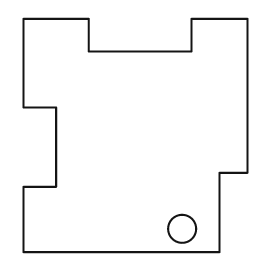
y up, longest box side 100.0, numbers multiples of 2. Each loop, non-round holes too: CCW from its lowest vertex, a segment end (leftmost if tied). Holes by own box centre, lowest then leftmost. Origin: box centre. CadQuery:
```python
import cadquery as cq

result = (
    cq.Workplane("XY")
    .moveTo(-48.0, -50.0)
    .lineTo(36.0, -50.0)
    .lineTo(36.0, -16.0)
    .lineTo(48.0, -16.0)
    .lineTo(48.0, 50.0)
    .lineTo(24.0, 50.0)
    .lineTo(24.0, 36.0)
    .lineTo(-20.0, 36.0)
    .lineTo(-20.0, 50.0)
    .lineTo(-48.0, 50.0)
    .lineTo(-48.0, 12.0)
    .lineTo(-34.0, 12.0)
    .lineTo(-34.0, -22.0)
    .lineTo(-48.0, -22.0)
    .close()
    .moveTo(20.0, -40.0)
    .circle(6.0)
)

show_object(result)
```